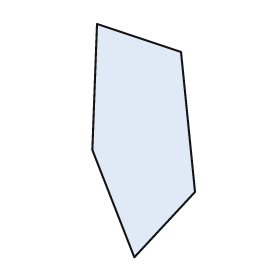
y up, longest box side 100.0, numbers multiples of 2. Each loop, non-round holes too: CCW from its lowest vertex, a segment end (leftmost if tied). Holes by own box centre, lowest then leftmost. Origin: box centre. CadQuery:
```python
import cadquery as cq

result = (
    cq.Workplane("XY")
    .moveTo(-4.0, -50.0)
    .lineTo(22.0, -22.0)
    .lineTo(16.0, 38.0)
    .lineTo(-20.0, 50.0)
    .lineTo(-22.0, -4.0)
    .close()
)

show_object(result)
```